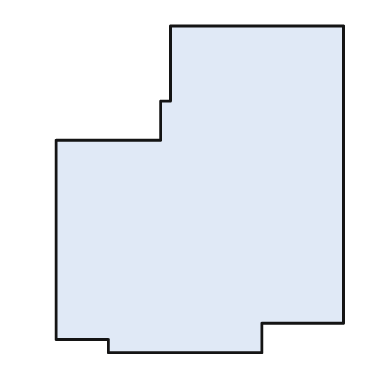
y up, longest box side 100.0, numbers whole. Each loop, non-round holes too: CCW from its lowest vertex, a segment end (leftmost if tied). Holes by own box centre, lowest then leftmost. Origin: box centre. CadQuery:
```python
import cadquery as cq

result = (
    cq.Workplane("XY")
    .moveTo(-28.0, -50.0)
    .lineTo(19.0, -50.0)
    .lineTo(19.0, -41.0)
    .lineTo(44.0, -41.0)
    .lineTo(44.0, 50.0)
    .lineTo(-9.0, 50.0)
    .lineTo(-9.0, 27.0)
    .lineTo(-12.0, 27.0)
    .lineTo(-12.0, 15.0)
    .lineTo(-44.0, 15.0)
    .lineTo(-44.0, -46.0)
    .lineTo(-28.0, -46.0)
    .close()
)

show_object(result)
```